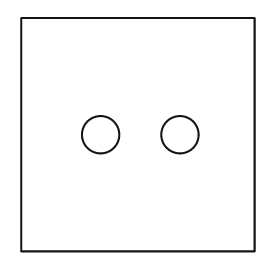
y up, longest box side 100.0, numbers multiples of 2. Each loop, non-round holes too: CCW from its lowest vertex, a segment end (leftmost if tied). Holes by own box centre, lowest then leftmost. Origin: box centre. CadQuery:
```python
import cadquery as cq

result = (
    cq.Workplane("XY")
    .moveTo(-50.0, -50.0)
    .lineTo(50.0, -50.0)
    .lineTo(50.0, 50.0)
    .lineTo(-50.0, 50.0)
    .close()
    .moveTo(-16.0, 0.0)
    .circle(8.0)
    .moveTo(18.0, 0.0)
    .circle(8.0)
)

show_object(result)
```